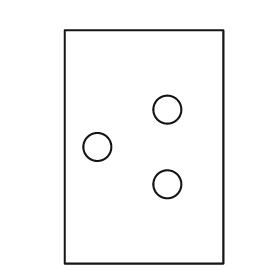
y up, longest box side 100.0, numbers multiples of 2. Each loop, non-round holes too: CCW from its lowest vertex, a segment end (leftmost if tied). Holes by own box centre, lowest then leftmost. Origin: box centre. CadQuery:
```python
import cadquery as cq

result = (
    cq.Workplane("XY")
    .moveTo(-34.0, -50.0)
    .lineTo(34.0, -50.0)
    .lineTo(34.0, 50.0)
    .lineTo(-34.0, 50.0)
    .close()
    .moveTo(10.0, -16.0)
    .circle(6.0)
    .moveTo(-20.0, 0.0)
    .circle(6.0)
    .moveTo(10.0, 16.0)
    .circle(6.0)
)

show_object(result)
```